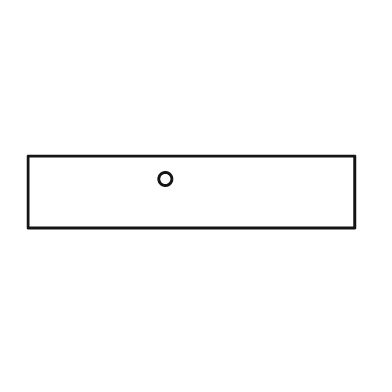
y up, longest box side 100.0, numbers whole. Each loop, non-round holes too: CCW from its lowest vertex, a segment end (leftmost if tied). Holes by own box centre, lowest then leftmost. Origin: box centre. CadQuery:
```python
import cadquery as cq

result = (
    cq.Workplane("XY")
    .moveTo(-50.0, -11.0)
    .lineTo(50.0, -11.0)
    .lineTo(50.0, 11.0)
    .lineTo(-50.0, 11.0)
    .close()
    .moveTo(-8.0, 4.0)
    .circle(2.0)
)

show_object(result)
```